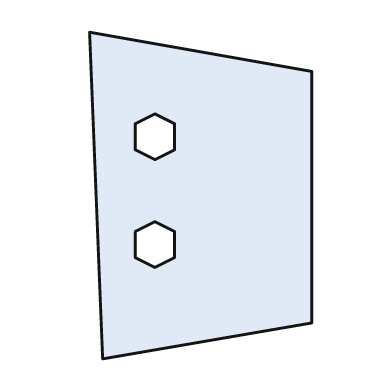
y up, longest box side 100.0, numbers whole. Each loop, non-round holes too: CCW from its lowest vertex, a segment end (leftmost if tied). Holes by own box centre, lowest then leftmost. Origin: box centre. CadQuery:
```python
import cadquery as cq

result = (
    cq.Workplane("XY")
    .moveTo(-30.0, -50.0)
    .lineTo(34.0, -39.0)
    .lineTo(34.0, 38.0)
    .lineTo(-34.0, 50.0)
    .close()
    .moveTo(-14.0, -22.0)
    .lineTo(-8.0, -19.0)
    .lineTo(-8.0, -11.0)
    .lineTo(-14.0, -8.0)
    .lineTo(-20.0, -11.0)
    .lineTo(-20.0, -19.0)
    .close()
    .moveTo(-14.0, 11.0)
    .lineTo(-8.0, 14.0)
    .lineTo(-8.0, 22.0)
    .lineTo(-14.0, 25.0)
    .lineTo(-20.0, 22.0)
    .lineTo(-20.0, 14.0)
    .close()
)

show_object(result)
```